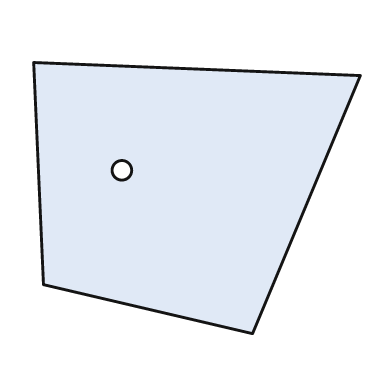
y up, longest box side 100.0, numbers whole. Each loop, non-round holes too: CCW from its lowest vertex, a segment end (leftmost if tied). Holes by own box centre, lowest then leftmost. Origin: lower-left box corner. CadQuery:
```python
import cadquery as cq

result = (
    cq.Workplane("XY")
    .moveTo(67.0, 0.0)
    .lineTo(100.0, 79.0)
    .lineTo(0.0, 83.0)
    .lineTo(3.0, 15.0)
    .close()
    .moveTo(27.0, 50.0)
    .circle(3.0)
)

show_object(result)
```